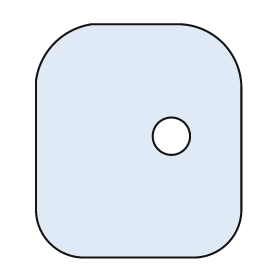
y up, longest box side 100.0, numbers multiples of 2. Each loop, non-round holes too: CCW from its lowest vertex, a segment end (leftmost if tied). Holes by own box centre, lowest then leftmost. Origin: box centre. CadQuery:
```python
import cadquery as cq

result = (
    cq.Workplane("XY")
    .moveTo(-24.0, -50.0)
    .lineTo(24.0, -50.0)
    .threePointArc((38.0, -44.0), (44.0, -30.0))
    .lineTo(44.0, 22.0)
    .threePointArc((36.0, 42.0), (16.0, 50.0))
    .lineTo(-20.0, 50.0)
    .threePointArc((-36.0, 42.0), (-44.0, 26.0))
    .lineTo(-44.0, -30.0)
    .threePointArc((-38.0, -44.0), (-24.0, -50.0))
    .close()
    .moveTo(14.0, 2.0)
    .circle(8.0)
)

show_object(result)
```